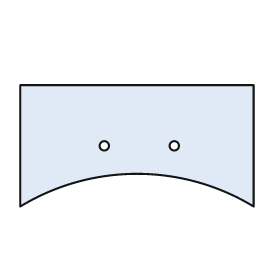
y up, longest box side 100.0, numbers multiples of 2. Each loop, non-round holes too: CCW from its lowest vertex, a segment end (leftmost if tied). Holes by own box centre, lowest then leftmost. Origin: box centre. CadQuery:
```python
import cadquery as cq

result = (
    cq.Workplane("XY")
    .moveTo(-50.0, -26.0)
    .threePointArc((0.0, -12.0), (50.0, -26.0))
    .lineTo(50.0, 26.0)
    .lineTo(-50.0, 26.0)
    .close()
    .moveTo(-14.0, 0.0)
    .circle(2.0)
    .moveTo(16.0, 0.0)
    .circle(2.0)
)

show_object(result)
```